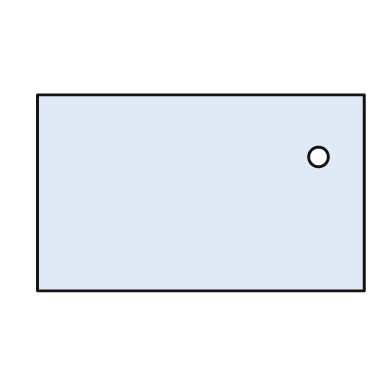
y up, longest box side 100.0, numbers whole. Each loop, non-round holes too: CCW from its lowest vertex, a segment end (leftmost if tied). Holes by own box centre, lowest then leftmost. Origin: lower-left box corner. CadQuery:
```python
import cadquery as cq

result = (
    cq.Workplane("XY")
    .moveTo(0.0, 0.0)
    .lineTo(100.0, 0.0)
    .lineTo(100.0, 60.0)
    .lineTo(0.0, 60.0)
    .close()
    .moveTo(86.0, 41.0)
    .circle(3.0)
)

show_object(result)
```